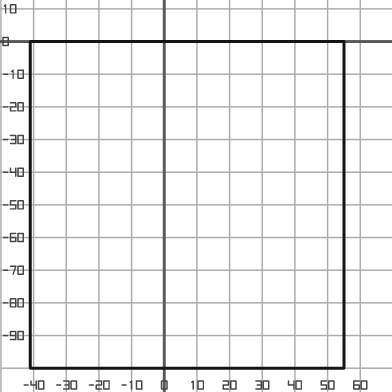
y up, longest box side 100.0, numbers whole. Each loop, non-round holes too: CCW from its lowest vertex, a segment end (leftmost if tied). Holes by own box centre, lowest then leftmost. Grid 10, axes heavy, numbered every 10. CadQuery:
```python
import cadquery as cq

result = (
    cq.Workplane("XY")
    .moveTo(-41.0, -100.0)
    .lineTo(55.0, -100.0)
    .lineTo(55.0, 0.0)
    .lineTo(-41.0, 0.0)
    .close()
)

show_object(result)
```